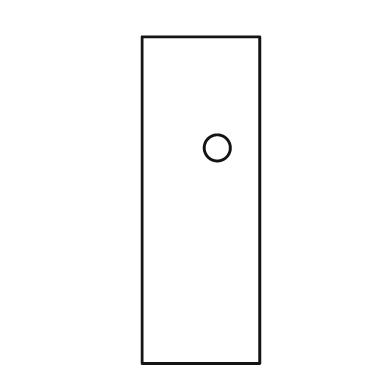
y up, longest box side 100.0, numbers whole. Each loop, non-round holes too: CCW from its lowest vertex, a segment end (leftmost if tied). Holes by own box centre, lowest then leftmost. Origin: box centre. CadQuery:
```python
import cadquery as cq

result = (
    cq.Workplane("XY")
    .moveTo(-18.0, -50.0)
    .lineTo(18.0, -50.0)
    .lineTo(18.0, 50.0)
    .lineTo(-18.0, 50.0)
    .close()
    .moveTo(5.0, 16.0)
    .circle(4.0)
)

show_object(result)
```